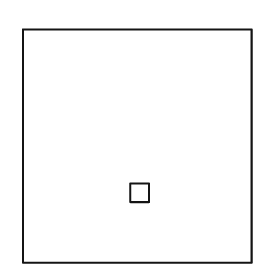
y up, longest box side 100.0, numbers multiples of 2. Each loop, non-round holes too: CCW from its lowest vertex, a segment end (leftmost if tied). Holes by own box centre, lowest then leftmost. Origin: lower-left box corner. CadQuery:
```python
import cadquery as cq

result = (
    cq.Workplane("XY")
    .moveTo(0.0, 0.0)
    .lineTo(98.0, 0.0)
    .lineTo(98.0, 100.0)
    .lineTo(0.0, 100.0)
    .close()
    .moveTo(46.0, 26.0)
    .lineTo(54.0, 26.0)
    .lineTo(54.0, 34.0)
    .lineTo(46.0, 34.0)
    .close()
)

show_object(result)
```